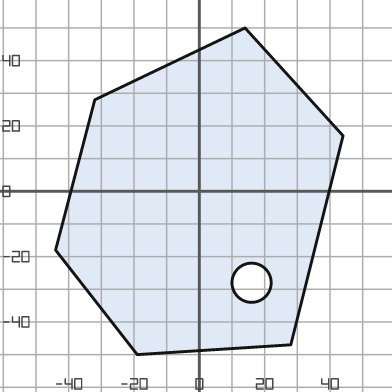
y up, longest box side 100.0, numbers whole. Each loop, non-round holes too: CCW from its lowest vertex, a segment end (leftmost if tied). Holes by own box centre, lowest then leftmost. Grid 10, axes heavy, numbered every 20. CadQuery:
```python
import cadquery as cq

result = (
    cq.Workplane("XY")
    .moveTo(-19.0, -50.0)
    .lineTo(28.0, -47.0)
    .lineTo(44.0, 17.0)
    .lineTo(14.0, 50.0)
    .lineTo(-32.0, 28.0)
    .lineTo(-44.0, -18.0)
    .close()
    .moveTo(16.0, -28.0)
    .circle(6.0)
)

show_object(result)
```